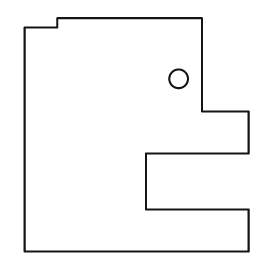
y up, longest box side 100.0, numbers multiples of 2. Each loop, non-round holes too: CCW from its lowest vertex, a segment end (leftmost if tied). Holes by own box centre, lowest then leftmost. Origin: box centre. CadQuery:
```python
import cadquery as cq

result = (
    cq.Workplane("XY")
    .moveTo(-48.0, -50.0)
    .lineTo(48.0, -50.0)
    .lineTo(48.0, -32.0)
    .lineTo(4.0, -32.0)
    .lineTo(4.0, -8.0)
    .lineTo(48.0, -8.0)
    .lineTo(48.0, 10.0)
    .lineTo(28.0, 10.0)
    .lineTo(28.0, 50.0)
    .lineTo(-34.0, 50.0)
    .lineTo(-34.0, 46.0)
    .lineTo(-48.0, 46.0)
    .close()
    .moveTo(18.0, 24.0)
    .circle(4.0)
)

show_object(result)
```